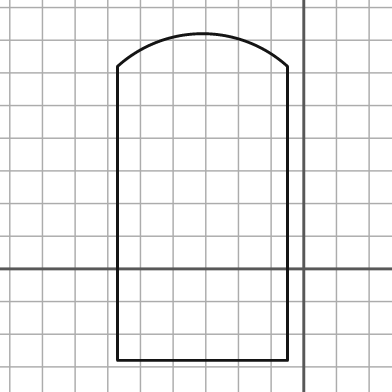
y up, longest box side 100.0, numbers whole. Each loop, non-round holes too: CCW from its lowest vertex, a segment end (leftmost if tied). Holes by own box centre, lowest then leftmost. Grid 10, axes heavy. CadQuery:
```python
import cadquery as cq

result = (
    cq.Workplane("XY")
    .moveTo(-57.0, -28.0)
    .lineTo(-5.0, -28.0)
    .lineTo(-5.0, 62.0)
    .threePointArc((-31.0, 72.0), (-57.0, 62.0))
    .close()
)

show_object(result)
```